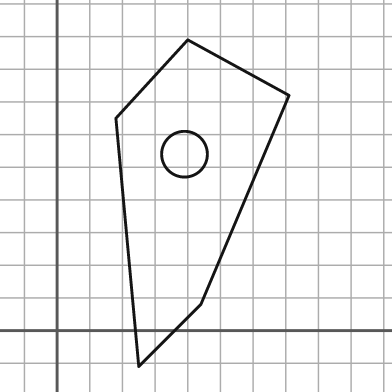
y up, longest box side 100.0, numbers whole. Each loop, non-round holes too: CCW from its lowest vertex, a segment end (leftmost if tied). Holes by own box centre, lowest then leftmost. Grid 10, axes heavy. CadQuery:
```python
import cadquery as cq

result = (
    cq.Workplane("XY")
    .moveTo(25.0, -11.0)
    .lineTo(44.0, 8.0)
    .lineTo(71.0, 72.0)
    .lineTo(40.0, 89.0)
    .lineTo(18.0, 65.0)
    .close()
    .moveTo(39.0, 54.0)
    .circle(7.0)
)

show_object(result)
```